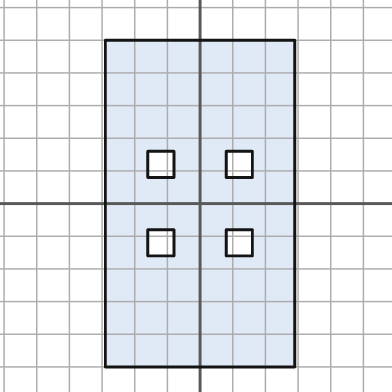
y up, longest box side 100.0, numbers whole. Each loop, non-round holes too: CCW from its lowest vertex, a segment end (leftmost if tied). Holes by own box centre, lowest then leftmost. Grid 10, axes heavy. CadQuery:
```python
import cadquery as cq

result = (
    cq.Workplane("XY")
    .moveTo(-29.0, -50.0)
    .lineTo(29.0, -50.0)
    .lineTo(29.0, 50.0)
    .lineTo(-29.0, 50.0)
    .close()
    .moveTo(-16.0, -16.0)
    .lineTo(-8.0, -16.0)
    .lineTo(-8.0, -8.0)
    .lineTo(-16.0, -8.0)
    .close()
    .moveTo(8.0, -16.0)
    .lineTo(16.0, -16.0)
    .lineTo(16.0, -8.0)
    .lineTo(8.0, -8.0)
    .close()
    .moveTo(-16.0, 8.0)
    .lineTo(-8.0, 8.0)
    .lineTo(-8.0, 16.0)
    .lineTo(-16.0, 16.0)
    .close()
    .moveTo(8.0, 8.0)
    .lineTo(16.0, 8.0)
    .lineTo(16.0, 16.0)
    .lineTo(8.0, 16.0)
    .close()
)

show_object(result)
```